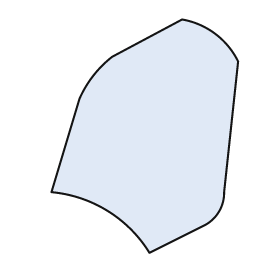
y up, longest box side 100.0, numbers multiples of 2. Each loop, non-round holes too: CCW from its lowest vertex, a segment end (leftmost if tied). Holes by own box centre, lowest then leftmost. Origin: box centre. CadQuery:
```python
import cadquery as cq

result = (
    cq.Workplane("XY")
    .moveTo(2.0, -50.0)
    .lineTo(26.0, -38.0)
    .threePointArc((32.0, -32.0), (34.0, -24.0))
    .lineTo(40.0, 32.0)
    .threePointArc((30.0, 44.0), (16.0, 50.0))
    .lineTo(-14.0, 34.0)
    .threePointArc((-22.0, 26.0), (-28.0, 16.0))
    .lineTo(-40.0, -24.0)
    .threePointArc((-16.0, -32.0), (2.0, -50.0))
    .close()
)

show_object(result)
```